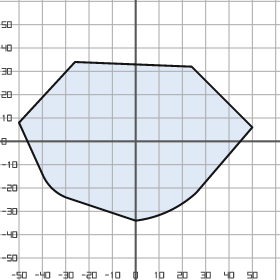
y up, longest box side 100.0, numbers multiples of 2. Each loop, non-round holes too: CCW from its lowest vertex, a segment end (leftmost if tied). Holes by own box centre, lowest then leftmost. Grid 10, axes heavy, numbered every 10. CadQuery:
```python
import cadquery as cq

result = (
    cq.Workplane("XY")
    .moveTo(0.0, -34.0)
    .threePointArc((14.0, -30.0), (26.0, -22.0))
    .lineTo(50.0, 6.0)
    .lineTo(24.0, 32.0)
    .lineTo(-26.0, 34.0)
    .lineTo(-50.0, 8.0)
    .lineTo(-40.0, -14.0)
    .threePointArc((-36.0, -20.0), (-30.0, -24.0))
    .close()
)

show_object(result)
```